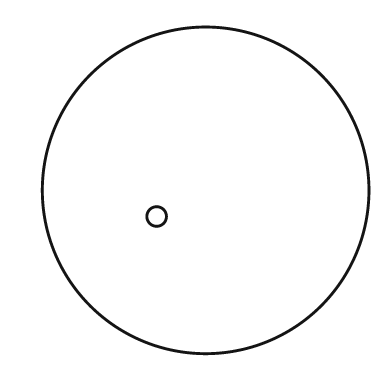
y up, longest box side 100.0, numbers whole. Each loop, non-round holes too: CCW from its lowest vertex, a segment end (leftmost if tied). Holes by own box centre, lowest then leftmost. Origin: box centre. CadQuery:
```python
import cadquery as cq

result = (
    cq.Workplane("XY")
    .moveTo(0.0, 0.0)
    .circle(50.0)
    .moveTo(-15.0, -8.0)
    .circle(3.0)
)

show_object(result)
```